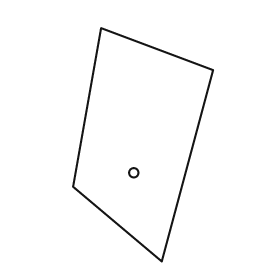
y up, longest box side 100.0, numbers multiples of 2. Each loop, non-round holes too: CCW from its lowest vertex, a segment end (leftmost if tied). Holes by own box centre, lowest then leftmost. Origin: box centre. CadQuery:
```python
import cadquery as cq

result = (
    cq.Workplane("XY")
    .moveTo(8.0, -50.0)
    .lineTo(30.0, 32.0)
    .lineTo(-18.0, 50.0)
    .lineTo(-30.0, -18.0)
    .close()
    .moveTo(-4.0, -12.0)
    .circle(2.0)
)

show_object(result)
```